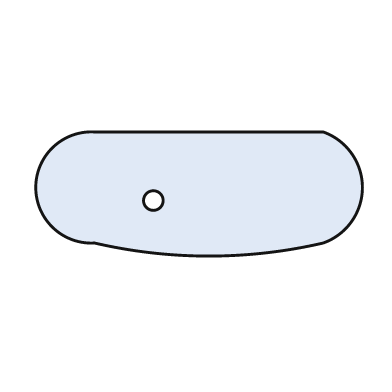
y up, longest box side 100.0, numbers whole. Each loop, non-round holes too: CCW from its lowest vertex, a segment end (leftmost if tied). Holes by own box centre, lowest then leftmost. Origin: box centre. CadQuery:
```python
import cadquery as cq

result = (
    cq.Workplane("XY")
    .moveTo(-32.0, -15.0)
    .threePointArc((3.0, -19.0), (38.0, -15.0))
    .threePointArc((50.0, 2.0), (38.0, 19.0))
    .lineTo(-32.0, 19.0)
    .threePointArc((-50.0, 2.0), (-32.0, -15.0))
    .close()
    .moveTo(-14.0, -2.0)
    .circle(3.0)
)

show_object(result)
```